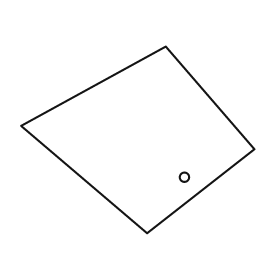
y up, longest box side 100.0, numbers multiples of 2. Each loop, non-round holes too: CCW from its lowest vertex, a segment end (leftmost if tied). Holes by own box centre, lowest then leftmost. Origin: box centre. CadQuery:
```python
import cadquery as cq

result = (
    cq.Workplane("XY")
    .moveTo(4.0, -40.0)
    .lineTo(50.0, -4.0)
    .lineTo(12.0, 40.0)
    .lineTo(-50.0, 6.0)
    .close()
    .moveTo(20.0, -16.0)
    .circle(2.0)
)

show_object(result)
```